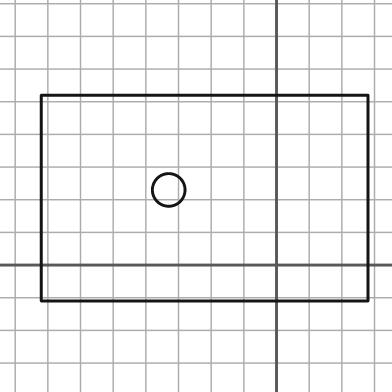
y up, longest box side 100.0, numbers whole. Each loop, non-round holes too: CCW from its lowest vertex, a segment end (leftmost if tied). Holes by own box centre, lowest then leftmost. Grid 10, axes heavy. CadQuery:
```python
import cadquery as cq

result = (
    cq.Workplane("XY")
    .moveTo(-72.0, -11.0)
    .lineTo(28.0, -11.0)
    .lineTo(28.0, 52.0)
    .lineTo(-72.0, 52.0)
    .close()
    .moveTo(-33.0, 23.0)
    .circle(5.0)
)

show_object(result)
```